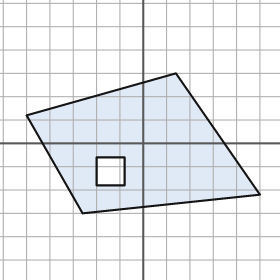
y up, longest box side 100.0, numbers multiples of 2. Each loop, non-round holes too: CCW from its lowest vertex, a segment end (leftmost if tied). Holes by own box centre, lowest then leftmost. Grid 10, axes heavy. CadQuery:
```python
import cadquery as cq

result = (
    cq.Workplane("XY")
    .moveTo(-26.0, -30.0)
    .lineTo(50.0, -22.0)
    .lineTo(14.0, 30.0)
    .lineTo(-50.0, 12.0)
    .close()
    .moveTo(-20.0, -18.0)
    .lineTo(-8.0, -18.0)
    .lineTo(-8.0, -6.0)
    .lineTo(-20.0, -6.0)
    .close()
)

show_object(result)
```